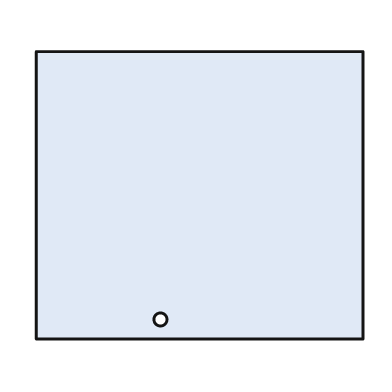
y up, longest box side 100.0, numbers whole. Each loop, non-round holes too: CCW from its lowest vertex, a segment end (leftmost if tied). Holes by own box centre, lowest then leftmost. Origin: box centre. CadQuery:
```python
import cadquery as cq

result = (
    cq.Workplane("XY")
    .moveTo(-50.0, -44.0)
    .lineTo(50.0, -44.0)
    .lineTo(50.0, 44.0)
    .lineTo(-50.0, 44.0)
    .close()
    .moveTo(-12.0, -38.0)
    .circle(2.0)
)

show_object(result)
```